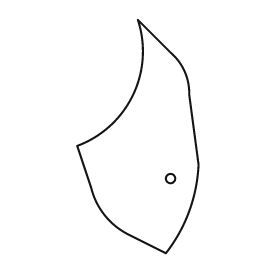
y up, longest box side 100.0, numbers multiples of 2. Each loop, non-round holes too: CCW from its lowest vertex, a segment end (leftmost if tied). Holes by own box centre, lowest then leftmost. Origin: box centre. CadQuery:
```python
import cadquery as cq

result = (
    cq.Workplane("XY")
    .moveTo(12.0, -50.0)
    .threePointArc((22.0, -32.0), (26.0, -12.0))
    .lineTo(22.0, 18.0)
    .threePointArc((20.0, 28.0), (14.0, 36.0))
    .lineTo(0.0, 50.0)
    .threePointArc((-2.0, 18.0), (-26.0, -4.0))
    .lineTo(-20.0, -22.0)
    .threePointArc((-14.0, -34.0), (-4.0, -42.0))
    .close()
    .moveTo(14.0, -18.0)
    .circle(2.0)
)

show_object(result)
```